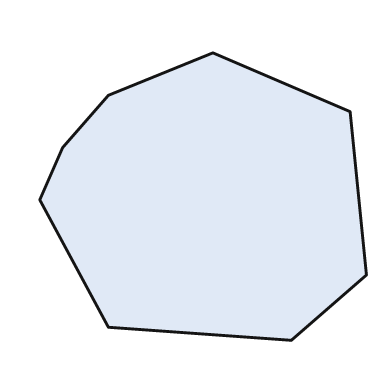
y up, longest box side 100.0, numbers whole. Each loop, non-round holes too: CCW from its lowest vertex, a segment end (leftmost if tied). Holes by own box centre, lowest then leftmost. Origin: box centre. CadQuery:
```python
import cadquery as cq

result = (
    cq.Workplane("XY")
    .moveTo(27.0, -44.0)
    .lineTo(50.0, -24.0)
    .lineTo(45.0, 26.0)
    .lineTo(3.0, 44.0)
    .lineTo(-29.0, 31.0)
    .lineTo(-43.0, 15.0)
    .lineTo(-50.0, -1.0)
    .lineTo(-29.0, -40.0)
    .close()
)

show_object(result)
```